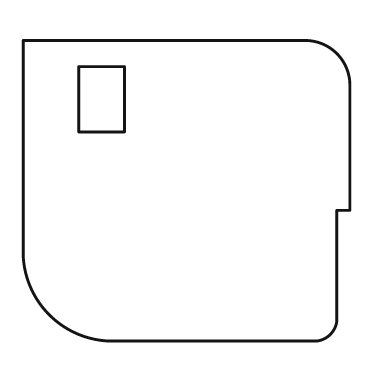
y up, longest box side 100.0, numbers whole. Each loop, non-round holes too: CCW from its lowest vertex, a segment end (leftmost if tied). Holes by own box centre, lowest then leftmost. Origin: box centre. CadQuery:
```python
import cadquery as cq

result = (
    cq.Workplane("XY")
    .moveTo(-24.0, -46.0)
    .lineTo(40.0, -46.0)
    .threePointArc((44.0, -44.0), (46.0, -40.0))
    .lineTo(46.0, -6.0)
    .lineTo(50.0, -6.0)
    .lineTo(50.0, 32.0)
    .threePointArc((46.0, 42.0), (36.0, 46.0))
    .lineTo(-50.0, 46.0)
    .lineTo(-50.0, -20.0)
    .threePointArc((-42.0, -38.0), (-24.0, -46.0))
    .close()
    .moveTo(-33.0, 18.0)
    .lineTo(-19.0, 18.0)
    .lineTo(-19.0, 38.0)
    .lineTo(-33.0, 38.0)
    .close()
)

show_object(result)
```